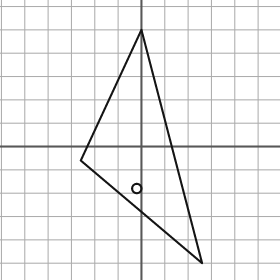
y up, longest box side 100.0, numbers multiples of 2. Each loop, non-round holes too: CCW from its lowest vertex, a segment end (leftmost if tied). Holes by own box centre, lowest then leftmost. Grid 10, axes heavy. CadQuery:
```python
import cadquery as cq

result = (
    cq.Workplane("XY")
    .moveTo(26.0, -50.0)
    .lineTo(0.0, 50.0)
    .lineTo(-26.0, -6.0)
    .close()
    .moveTo(-2.0, -18.0)
    .circle(2.0)
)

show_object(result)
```